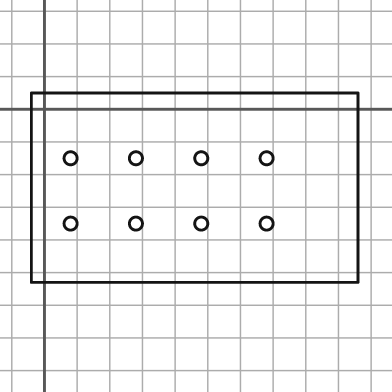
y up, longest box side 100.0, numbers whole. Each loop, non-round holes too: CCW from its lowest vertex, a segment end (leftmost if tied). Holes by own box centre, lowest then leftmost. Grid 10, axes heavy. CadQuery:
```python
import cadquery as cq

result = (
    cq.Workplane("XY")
    .moveTo(-4.0, -53.0)
    .lineTo(96.0, -53.0)
    .lineTo(96.0, 5.0)
    .lineTo(-4.0, 5.0)
    .close()
    .moveTo(8.0, -35.0)
    .circle(2.0)
    .moveTo(28.0, -35.0)
    .circle(2.0)
    .moveTo(48.0, -35.0)
    .circle(2.0)
    .moveTo(68.0, -35.0)
    .circle(2.0)
    .moveTo(8.0, -15.0)
    .circle(2.0)
    .moveTo(28.0, -15.0)
    .circle(2.0)
    .moveTo(48.0, -15.0)
    .circle(2.0)
    .moveTo(68.0, -15.0)
    .circle(2.0)
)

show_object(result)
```